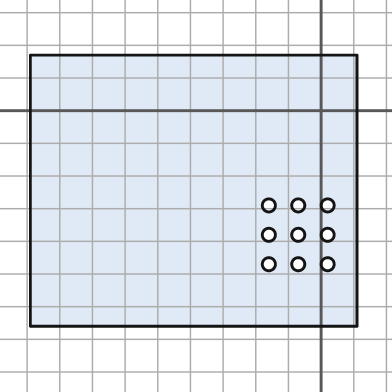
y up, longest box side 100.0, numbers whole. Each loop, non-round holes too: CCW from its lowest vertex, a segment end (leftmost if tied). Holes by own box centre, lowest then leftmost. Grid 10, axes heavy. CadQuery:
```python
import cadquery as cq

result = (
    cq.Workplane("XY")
    .moveTo(-89.0, -66.0)
    .lineTo(11.0, -66.0)
    .lineTo(11.0, 17.0)
    .lineTo(-89.0, 17.0)
    .close()
    .moveTo(-16.0, -47.0)
    .circle(2.0)
    .moveTo(-7.0, -47.0)
    .circle(2.0)
    .moveTo(2.0, -47.0)
    .circle(2.0)
    .moveTo(-16.0, -38.0)
    .circle(2.0)
    .moveTo(-7.0, -38.0)
    .circle(2.0)
    .moveTo(2.0, -38.0)
    .circle(2.0)
    .moveTo(-16.0, -29.0)
    .circle(2.0)
    .moveTo(-7.0, -29.0)
    .circle(2.0)
    .moveTo(2.0, -29.0)
    .circle(2.0)
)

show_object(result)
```